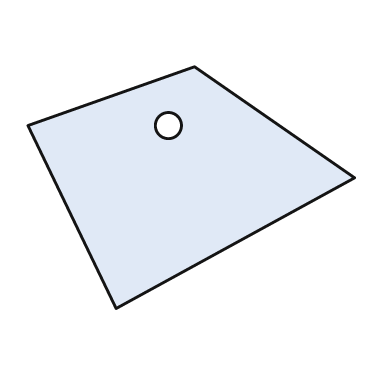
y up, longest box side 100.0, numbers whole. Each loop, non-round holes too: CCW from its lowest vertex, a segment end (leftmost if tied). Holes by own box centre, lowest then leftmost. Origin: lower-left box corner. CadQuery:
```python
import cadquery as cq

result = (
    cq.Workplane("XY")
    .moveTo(27.0, 0.0)
    .lineTo(100.0, 40.0)
    .lineTo(51.0, 74.0)
    .lineTo(0.0, 56.0)
    .close()
    .moveTo(43.0, 56.0)
    .circle(4.0)
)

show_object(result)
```